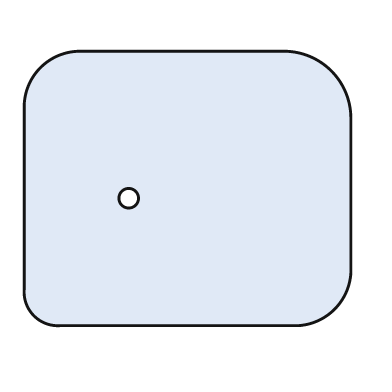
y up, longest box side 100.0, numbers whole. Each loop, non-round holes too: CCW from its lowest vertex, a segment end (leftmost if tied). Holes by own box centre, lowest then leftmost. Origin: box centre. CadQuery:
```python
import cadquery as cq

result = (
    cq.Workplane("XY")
    .moveTo(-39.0, -42.0)
    .lineTo(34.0, -42.0)
    .threePointArc((45.0, -37.0), (50.0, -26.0))
    .lineTo(50.0, 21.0)
    .threePointArc((44.0, 36.0), (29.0, 42.0))
    .lineTo(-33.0, 42.0)
    .threePointArc((-45.0, 37.0), (-50.0, 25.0))
    .lineTo(-50.0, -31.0)
    .threePointArc((-47.0, -39.0), (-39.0, -42.0))
    .close()
    .moveTo(-18.0, -3.0)
    .circle(3.0)
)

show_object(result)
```